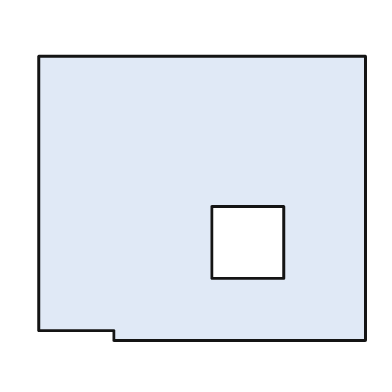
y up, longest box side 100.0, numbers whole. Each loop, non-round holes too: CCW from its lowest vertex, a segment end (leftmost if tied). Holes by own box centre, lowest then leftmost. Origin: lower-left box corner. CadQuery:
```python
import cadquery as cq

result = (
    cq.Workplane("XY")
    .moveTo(23.0, 0.0)
    .lineTo(100.0, 0.0)
    .lineTo(100.0, 87.0)
    .lineTo(0.0, 87.0)
    .lineTo(0.0, 3.0)
    .lineTo(23.0, 3.0)
    .close()
    .moveTo(53.0, 19.0)
    .lineTo(75.0, 19.0)
    .lineTo(75.0, 41.0)
    .lineTo(53.0, 41.0)
    .close()
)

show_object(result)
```